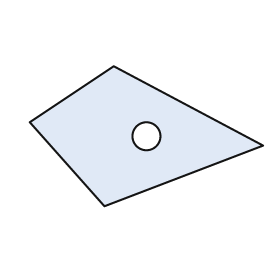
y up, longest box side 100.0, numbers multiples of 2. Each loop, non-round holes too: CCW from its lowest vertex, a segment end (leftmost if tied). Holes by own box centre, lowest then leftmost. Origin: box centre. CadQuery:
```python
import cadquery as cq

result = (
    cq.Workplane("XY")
    .moveTo(-18.0, -30.0)
    .lineTo(50.0, -4.0)
    .lineTo(-14.0, 30.0)
    .lineTo(-50.0, 6.0)
    .close()
    .moveTo(0.0, 0.0)
    .circle(6.0)
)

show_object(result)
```